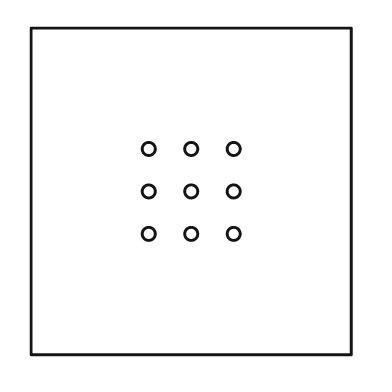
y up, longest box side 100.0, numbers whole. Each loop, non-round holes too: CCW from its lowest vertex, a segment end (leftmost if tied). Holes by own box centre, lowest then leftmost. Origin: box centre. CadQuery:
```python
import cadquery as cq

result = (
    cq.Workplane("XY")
    .moveTo(-49.0, -50.0)
    .lineTo(49.0, -50.0)
    .lineTo(49.0, 50.0)
    .lineTo(-49.0, 50.0)
    .close()
    .moveTo(-13.0, -13.0)
    .circle(2.0)
    .moveTo(0.0, -13.0)
    .circle(2.0)
    .moveTo(13.0, -13.0)
    .circle(2.0)
    .moveTo(-13.0, 0.0)
    .circle(2.0)
    .moveTo(0.0, 0.0)
    .circle(2.0)
    .moveTo(13.0, 0.0)
    .circle(2.0)
    .moveTo(-13.0, 13.0)
    .circle(2.0)
    .moveTo(0.0, 13.0)
    .circle(2.0)
    .moveTo(13.0, 13.0)
    .circle(2.0)
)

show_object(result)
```